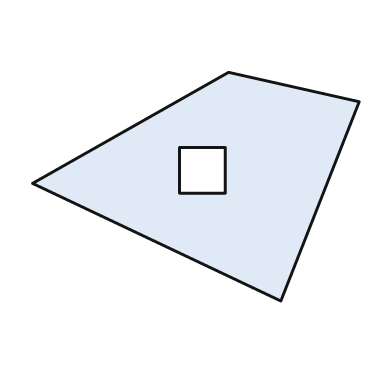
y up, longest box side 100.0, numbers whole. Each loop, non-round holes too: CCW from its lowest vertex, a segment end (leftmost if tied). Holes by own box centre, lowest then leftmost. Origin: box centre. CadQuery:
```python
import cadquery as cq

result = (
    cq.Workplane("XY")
    .moveTo(26.0, -35.0)
    .lineTo(50.0, 26.0)
    .lineTo(10.0, 35.0)
    .lineTo(-50.0, 1.0)
    .close()
    .moveTo(-5.0, -2.0)
    .lineTo(9.0, -2.0)
    .lineTo(9.0, 12.0)
    .lineTo(-5.0, 12.0)
    .close()
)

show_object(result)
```